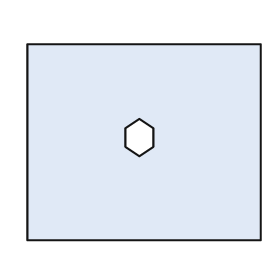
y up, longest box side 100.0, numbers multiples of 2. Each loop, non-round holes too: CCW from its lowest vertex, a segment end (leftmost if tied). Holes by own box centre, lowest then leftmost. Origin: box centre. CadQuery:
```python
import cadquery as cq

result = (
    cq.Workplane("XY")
    .moveTo(-50.0, -42.0)
    .lineTo(50.0, -42.0)
    .lineTo(50.0, 42.0)
    .lineTo(-50.0, 42.0)
    .close()
    .moveTo(-2.0, -6.0)
    .lineTo(4.0, -2.0)
    .lineTo(4.0, 6.0)
    .lineTo(-2.0, 10.0)
    .lineTo(-8.0, 6.0)
    .lineTo(-8.0, -2.0)
    .close()
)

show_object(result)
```